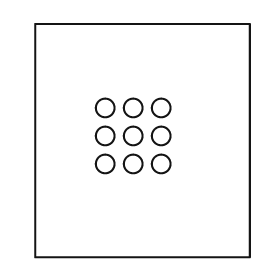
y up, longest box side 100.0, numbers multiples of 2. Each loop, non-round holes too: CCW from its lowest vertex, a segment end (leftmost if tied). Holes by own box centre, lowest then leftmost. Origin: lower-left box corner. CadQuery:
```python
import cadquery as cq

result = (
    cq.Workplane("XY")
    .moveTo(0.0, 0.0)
    .lineTo(92.0, 0.0)
    .lineTo(92.0, 100.0)
    .lineTo(0.0, 100.0)
    .close()
    .moveTo(30.0, 40.0)
    .circle(4.0)
    .moveTo(42.0, 40.0)
    .circle(4.0)
    .moveTo(54.0, 40.0)
    .circle(4.0)
    .moveTo(30.0, 52.0)
    .circle(4.0)
    .moveTo(42.0, 52.0)
    .circle(4.0)
    .moveTo(54.0, 52.0)
    .circle(4.0)
    .moveTo(30.0, 64.0)
    .circle(4.0)
    .moveTo(42.0, 64.0)
    .circle(4.0)
    .moveTo(54.0, 64.0)
    .circle(4.0)
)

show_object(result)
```